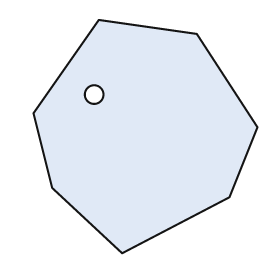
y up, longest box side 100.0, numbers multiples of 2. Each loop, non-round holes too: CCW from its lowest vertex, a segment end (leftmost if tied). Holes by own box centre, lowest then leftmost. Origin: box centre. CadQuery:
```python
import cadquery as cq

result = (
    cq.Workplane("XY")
    .moveTo(-10.0, -50.0)
    .lineTo(36.0, -26.0)
    .lineTo(48.0, 4.0)
    .lineTo(22.0, 44.0)
    .lineTo(-20.0, 50.0)
    .lineTo(-48.0, 10.0)
    .lineTo(-40.0, -22.0)
    .close()
    .moveTo(-22.0, 18.0)
    .circle(4.0)
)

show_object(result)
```